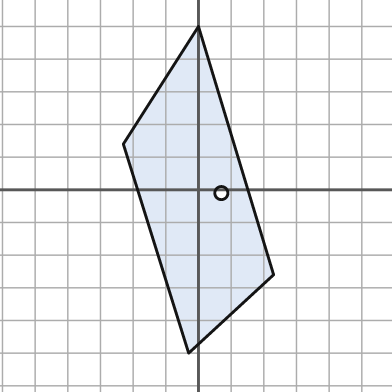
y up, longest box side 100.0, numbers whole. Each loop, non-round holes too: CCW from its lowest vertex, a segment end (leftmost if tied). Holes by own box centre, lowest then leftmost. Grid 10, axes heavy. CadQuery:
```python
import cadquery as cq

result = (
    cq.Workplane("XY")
    .moveTo(-3.0, -50.0)
    .lineTo(23.0, -26.0)
    .lineTo(0.0, 50.0)
    .lineTo(-23.0, 14.0)
    .close()
    .moveTo(7.0, -1.0)
    .circle(2.0)
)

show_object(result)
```